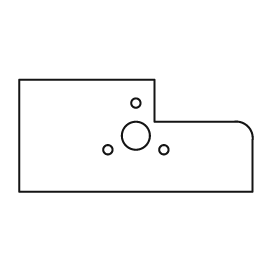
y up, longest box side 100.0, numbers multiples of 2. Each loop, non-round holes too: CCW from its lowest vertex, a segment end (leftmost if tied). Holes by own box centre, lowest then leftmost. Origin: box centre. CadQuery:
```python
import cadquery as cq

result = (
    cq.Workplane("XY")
    .moveTo(-50.0, -24.0)
    .lineTo(50.0, -24.0)
    .lineTo(50.0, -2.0)
    .threePointArc((48.0, 4.0), (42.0, 6.0))
    .lineTo(8.0, 6.0)
    .lineTo(8.0, 24.0)
    .lineTo(-50.0, 24.0)
    .close()
    .moveTo(-12.0, -6.0)
    .circle(2.0)
    .moveTo(12.0, -6.0)
    .circle(2.0)
    .moveTo(0.0, 0.0)
    .circle(6.0)
    .moveTo(0.0, 14.0)
    .circle(2.0)
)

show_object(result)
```